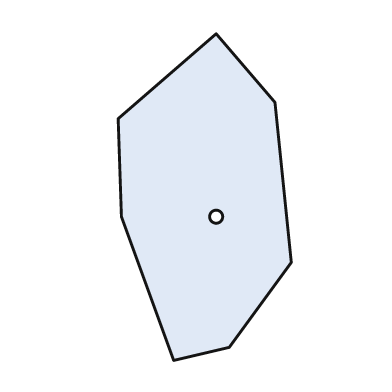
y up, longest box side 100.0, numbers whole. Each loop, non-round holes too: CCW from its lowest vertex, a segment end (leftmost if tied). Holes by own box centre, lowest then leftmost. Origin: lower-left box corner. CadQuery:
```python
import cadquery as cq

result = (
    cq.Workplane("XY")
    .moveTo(17.0, 0.0)
    .lineTo(34.0, 4.0)
    .lineTo(53.0, 30.0)
    .lineTo(48.0, 79.0)
    .lineTo(30.0, 100.0)
    .lineTo(0.0, 74.0)
    .lineTo(1.0, 44.0)
    .close()
    .moveTo(30.0, 44.0)
    .circle(2.0)
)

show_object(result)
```